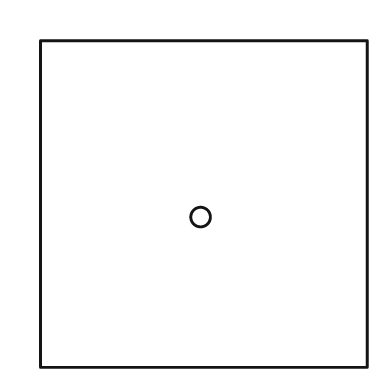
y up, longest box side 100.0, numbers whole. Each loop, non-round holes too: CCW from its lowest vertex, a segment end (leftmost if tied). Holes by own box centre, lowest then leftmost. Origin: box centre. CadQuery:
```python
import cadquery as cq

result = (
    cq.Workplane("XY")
    .moveTo(-50.0, -50.0)
    .lineTo(50.0, -50.0)
    .lineTo(50.0, 50.0)
    .lineTo(-50.0, 50.0)
    .close()
    .moveTo(-1.0, -4.0)
    .circle(3.0)
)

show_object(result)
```